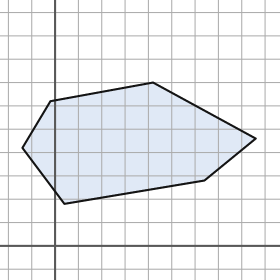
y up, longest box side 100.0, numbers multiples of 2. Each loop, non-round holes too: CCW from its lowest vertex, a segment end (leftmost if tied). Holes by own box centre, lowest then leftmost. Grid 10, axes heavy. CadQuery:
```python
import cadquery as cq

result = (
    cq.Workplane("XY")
    .moveTo(4.0, 18.0)
    .lineTo(64.0, 28.0)
    .lineTo(86.0, 46.0)
    .lineTo(42.0, 70.0)
    .lineTo(-2.0, 62.0)
    .lineTo(-14.0, 42.0)
    .close()
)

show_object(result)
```